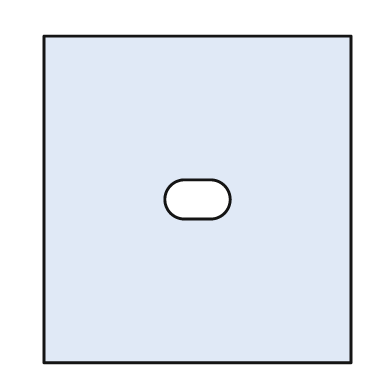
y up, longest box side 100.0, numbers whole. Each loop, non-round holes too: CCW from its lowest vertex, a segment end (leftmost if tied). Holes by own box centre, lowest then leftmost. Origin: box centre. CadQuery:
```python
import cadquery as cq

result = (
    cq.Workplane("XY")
    .moveTo(-47.0, -50.0)
    .lineTo(47.0, -50.0)
    .lineTo(47.0, 50.0)
    .lineTo(-47.0, 50.0)
    .close()
    .moveTo(-4.0, -6.0)
    .lineTo(4.0, -6.0)
    .threePointArc((10.0, 0.0), (4.0, 6.0))
    .lineTo(-4.0, 6.0)
    .threePointArc((-10.0, 0.0), (-4.0, -6.0))
    .close()
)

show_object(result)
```